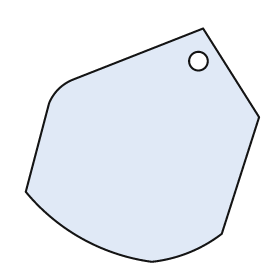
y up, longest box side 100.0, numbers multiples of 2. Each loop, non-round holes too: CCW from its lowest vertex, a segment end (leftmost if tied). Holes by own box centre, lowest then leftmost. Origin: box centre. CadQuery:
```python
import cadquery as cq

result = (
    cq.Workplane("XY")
    .moveTo(4.0, -50.0)
    .threePointArc((20.0, -46.0), (34.0, -38.0))
    .lineTo(50.0, 12.0)
    .lineTo(26.0, 50.0)
    .lineTo(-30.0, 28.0)
    .threePointArc((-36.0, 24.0), (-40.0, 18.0))
    .lineTo(-50.0, -20.0)
    .threePointArc((-26.0, -40.0), (4.0, -50.0))
    .close()
    .moveTo(24.0, 36.0)
    .circle(4.0)
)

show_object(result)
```